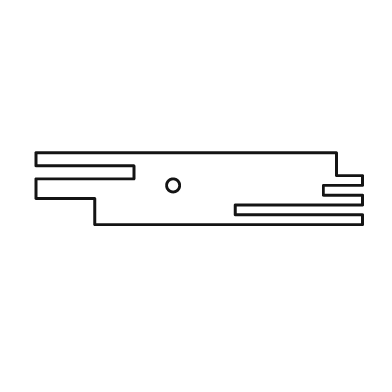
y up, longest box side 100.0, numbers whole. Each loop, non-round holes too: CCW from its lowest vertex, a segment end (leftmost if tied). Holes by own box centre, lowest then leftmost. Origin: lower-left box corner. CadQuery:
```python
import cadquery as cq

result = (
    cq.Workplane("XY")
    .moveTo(18.0, 0.0)
    .lineTo(100.0, 0.0)
    .lineTo(100.0, 3.0)
    .lineTo(61.0, 3.0)
    .lineTo(61.0, 6.0)
    .lineTo(100.0, 6.0)
    .lineTo(100.0, 9.0)
    .lineTo(88.0, 9.0)
    .lineTo(88.0, 12.0)
    .lineTo(100.0, 12.0)
    .lineTo(100.0, 15.0)
    .lineTo(92.0, 15.0)
    .lineTo(92.0, 22.0)
    .lineTo(0.0, 22.0)
    .lineTo(0.0, 18.0)
    .lineTo(30.0, 18.0)
    .lineTo(30.0, 14.0)
    .lineTo(0.0, 14.0)
    .lineTo(0.0, 8.0)
    .lineTo(18.0, 8.0)
    .close()
    .moveTo(42.0, 12.0)
    .circle(2.0)
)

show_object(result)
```